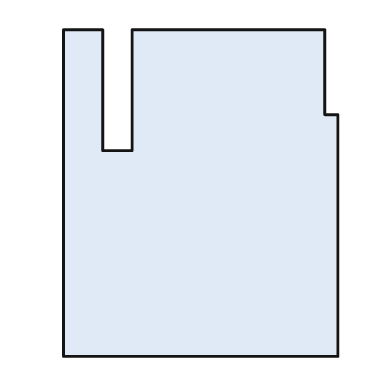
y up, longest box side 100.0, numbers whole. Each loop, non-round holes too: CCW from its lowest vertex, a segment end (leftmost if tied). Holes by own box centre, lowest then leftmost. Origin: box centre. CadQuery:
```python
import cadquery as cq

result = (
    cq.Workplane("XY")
    .moveTo(-42.0, -50.0)
    .lineTo(42.0, -50.0)
    .lineTo(42.0, 24.0)
    .lineTo(38.0, 24.0)
    .lineTo(38.0, 50.0)
    .lineTo(-21.0, 50.0)
    .lineTo(-21.0, 13.0)
    .lineTo(-30.0, 13.0)
    .lineTo(-30.0, 50.0)
    .lineTo(-42.0, 50.0)
    .close()
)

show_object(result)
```